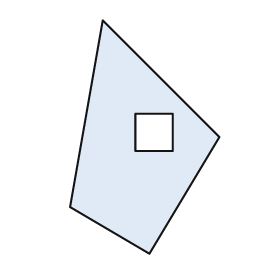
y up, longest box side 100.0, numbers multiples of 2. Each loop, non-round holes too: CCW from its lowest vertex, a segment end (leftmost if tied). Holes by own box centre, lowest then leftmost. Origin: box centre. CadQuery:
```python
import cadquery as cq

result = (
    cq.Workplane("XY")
    .moveTo(2.0, -50.0)
    .lineTo(32.0, 0.0)
    .lineTo(-18.0, 50.0)
    .lineTo(-32.0, -30.0)
    .close()
    .moveTo(-4.0, -6.0)
    .lineTo(12.0, -6.0)
    .lineTo(12.0, 10.0)
    .lineTo(-4.0, 10.0)
    .close()
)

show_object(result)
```